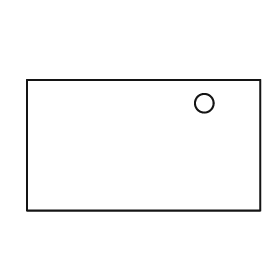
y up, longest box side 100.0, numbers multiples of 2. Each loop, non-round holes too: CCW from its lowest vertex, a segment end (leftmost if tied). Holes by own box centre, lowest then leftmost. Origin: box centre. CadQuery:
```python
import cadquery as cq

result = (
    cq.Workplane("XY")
    .moveTo(-50.0, -28.0)
    .lineTo(50.0, -28.0)
    .lineTo(50.0, 28.0)
    .lineTo(-50.0, 28.0)
    .close()
    .moveTo(26.0, 18.0)
    .circle(4.0)
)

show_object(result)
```